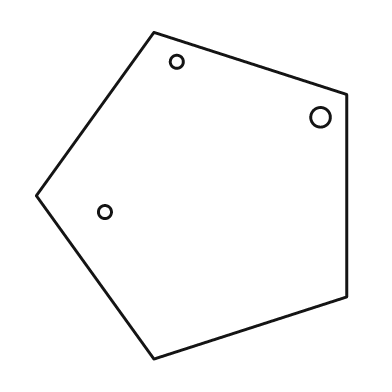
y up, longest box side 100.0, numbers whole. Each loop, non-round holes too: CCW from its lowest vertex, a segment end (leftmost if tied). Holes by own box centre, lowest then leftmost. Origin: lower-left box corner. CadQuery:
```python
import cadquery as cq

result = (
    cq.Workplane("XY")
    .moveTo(36.0, 0.0)
    .lineTo(95.0, 19.0)
    .lineTo(95.0, 81.0)
    .lineTo(36.0, 100.0)
    .lineTo(0.0, 50.0)
    .close()
    .moveTo(21.0, 45.0)
    .circle(2.0)
    .moveTo(87.0, 74.0)
    .circle(3.0)
    .moveTo(43.0, 91.0)
    .circle(2.0)
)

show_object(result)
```